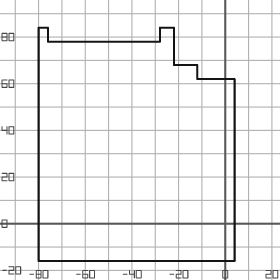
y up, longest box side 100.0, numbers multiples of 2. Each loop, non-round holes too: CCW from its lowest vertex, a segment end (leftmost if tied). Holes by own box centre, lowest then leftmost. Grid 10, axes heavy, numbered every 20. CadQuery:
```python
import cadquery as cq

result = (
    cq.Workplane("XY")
    .moveTo(-80.0, -16.0)
    .lineTo(4.0, -16.0)
    .lineTo(4.0, 62.0)
    .lineTo(-12.0, 62.0)
    .lineTo(-12.0, 68.0)
    .lineTo(-22.0, 68.0)
    .lineTo(-22.0, 84.0)
    .lineTo(-28.0, 84.0)
    .lineTo(-28.0, 78.0)
    .lineTo(-76.0, 78.0)
    .lineTo(-76.0, 84.0)
    .lineTo(-80.0, 84.0)
    .close()
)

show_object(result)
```